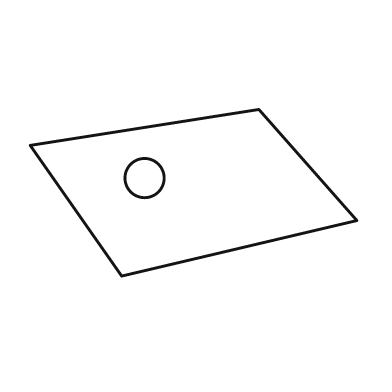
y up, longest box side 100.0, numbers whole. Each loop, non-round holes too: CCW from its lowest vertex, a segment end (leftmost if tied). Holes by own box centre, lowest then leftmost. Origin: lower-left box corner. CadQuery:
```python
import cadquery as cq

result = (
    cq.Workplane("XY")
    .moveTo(28.0, 0.0)
    .lineTo(100.0, 17.0)
    .lineTo(70.0, 51.0)
    .lineTo(0.0, 40.0)
    .close()
    .moveTo(35.0, 30.0)
    .circle(6.0)
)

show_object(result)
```